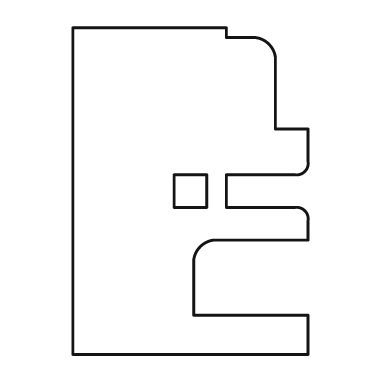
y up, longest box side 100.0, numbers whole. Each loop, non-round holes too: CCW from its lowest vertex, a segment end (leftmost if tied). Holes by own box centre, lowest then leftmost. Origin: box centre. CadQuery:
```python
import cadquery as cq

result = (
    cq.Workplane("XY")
    .moveTo(-36.0, -50.0)
    .lineTo(36.0, -50.0)
    .lineTo(36.0, -38.0)
    .lineTo(1.0, -38.0)
    .lineTo(1.0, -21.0)
    .threePointArc((3.0, -17.0), (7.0, -15.0))
    .lineTo(36.0, -15.0)
    .lineTo(36.0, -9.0)
    .threePointArc((35.0, -6.0), (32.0, -5.0))
    .lineTo(11.0, -5.0)
    .lineTo(11.0, 5.0)
    .lineTo(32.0, 5.0)
    .threePointArc((35.0, 6.0), (36.0, 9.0))
    .lineTo(36.0, 19.0)
    .lineTo(26.0, 19.0)
    .lineTo(26.0, 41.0)
    .threePointArc((24.0, 45.0), (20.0, 47.0))
    .lineTo(11.0, 47.0)
    .lineTo(11.0, 50.0)
    .lineTo(-36.0, 50.0)
    .close()
    .moveTo(-5.0, -5.0)
    .lineTo(5.0, -5.0)
    .lineTo(5.0, 5.0)
    .lineTo(-5.0, 5.0)
    .close()
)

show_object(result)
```